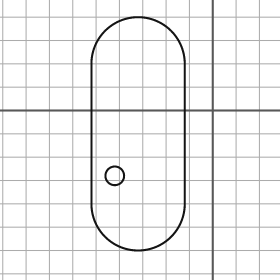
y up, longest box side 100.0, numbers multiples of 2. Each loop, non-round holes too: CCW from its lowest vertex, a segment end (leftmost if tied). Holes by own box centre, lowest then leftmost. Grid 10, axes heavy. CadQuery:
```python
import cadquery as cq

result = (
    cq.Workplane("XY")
    .moveTo(-52.0, -40.0)
    .threePointArc((-32.0, -60.0), (-12.0, -40.0))
    .lineTo(-12.0, 20.0)
    .threePointArc((-32.0, 40.0), (-52.0, 20.0))
    .close()
    .moveTo(-42.0, -28.0)
    .circle(4.0)
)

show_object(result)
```